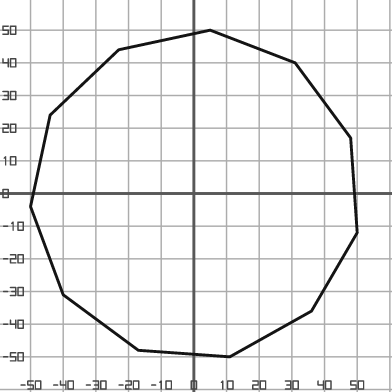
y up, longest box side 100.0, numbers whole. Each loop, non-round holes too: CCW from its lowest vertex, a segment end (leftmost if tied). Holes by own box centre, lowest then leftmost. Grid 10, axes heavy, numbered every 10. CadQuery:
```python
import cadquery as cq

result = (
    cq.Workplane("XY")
    .moveTo(11.0, -50.0)
    .lineTo(36.0, -36.0)
    .lineTo(50.0, -12.0)
    .lineTo(48.0, 17.0)
    .lineTo(31.0, 40.0)
    .lineTo(5.0, 50.0)
    .lineTo(-23.0, 44.0)
    .lineTo(-44.0, 24.0)
    .lineTo(-50.0, -4.0)
    .lineTo(-40.0, -31.0)
    .lineTo(-17.0, -48.0)
    .close()
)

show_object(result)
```